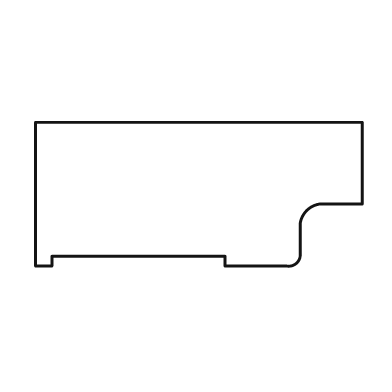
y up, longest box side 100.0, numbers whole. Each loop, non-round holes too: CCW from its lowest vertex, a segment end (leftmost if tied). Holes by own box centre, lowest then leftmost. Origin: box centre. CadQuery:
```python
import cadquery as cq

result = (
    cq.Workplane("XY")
    .moveTo(-50.0, -22.0)
    .lineTo(-45.0, -22.0)
    .lineTo(-45.0, -19.0)
    .lineTo(8.0, -19.0)
    .lineTo(8.0, -22.0)
    .lineTo(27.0, -22.0)
    .threePointArc((30.0, -21.0), (31.0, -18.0))
    .lineTo(31.0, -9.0)
    .threePointArc((33.0, -5.0), (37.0, -3.0))
    .lineTo(50.0, -3.0)
    .lineTo(50.0, 22.0)
    .lineTo(-50.0, 22.0)
    .close()
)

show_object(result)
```